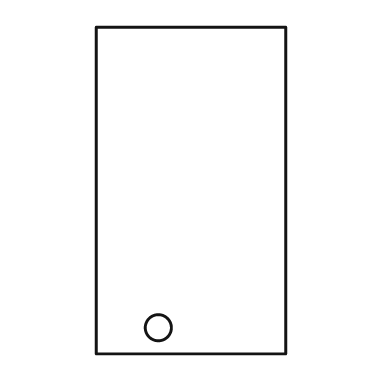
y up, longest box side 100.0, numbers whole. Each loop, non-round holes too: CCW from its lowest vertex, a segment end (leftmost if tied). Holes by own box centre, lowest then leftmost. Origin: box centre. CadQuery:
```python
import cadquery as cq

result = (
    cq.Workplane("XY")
    .moveTo(-29.0, -50.0)
    .lineTo(29.0, -50.0)
    .lineTo(29.0, 50.0)
    .lineTo(-29.0, 50.0)
    .close()
    .moveTo(-10.0, -42.0)
    .circle(4.0)
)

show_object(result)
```